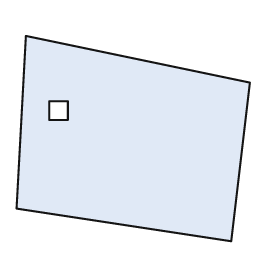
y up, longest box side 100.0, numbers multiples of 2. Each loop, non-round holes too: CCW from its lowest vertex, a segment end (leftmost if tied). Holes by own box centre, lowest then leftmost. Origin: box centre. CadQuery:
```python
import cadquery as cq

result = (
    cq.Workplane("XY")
    .moveTo(42.0, -44.0)
    .lineTo(50.0, 24.0)
    .lineTo(-46.0, 44.0)
    .lineTo(-50.0, -30.0)
    .close()
    .moveTo(-36.0, 8.0)
    .lineTo(-28.0, 8.0)
    .lineTo(-28.0, 16.0)
    .lineTo(-36.0, 16.0)
    .close()
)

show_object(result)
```